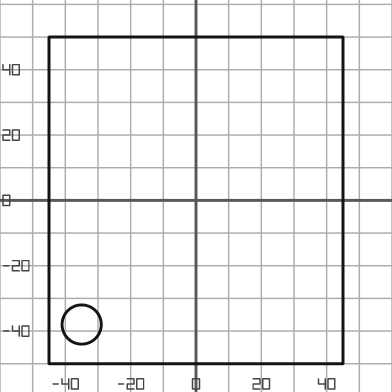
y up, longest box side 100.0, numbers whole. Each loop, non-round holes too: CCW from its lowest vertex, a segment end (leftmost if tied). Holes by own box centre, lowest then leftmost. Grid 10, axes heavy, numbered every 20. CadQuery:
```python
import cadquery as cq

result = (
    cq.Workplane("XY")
    .moveTo(-45.0, -50.0)
    .lineTo(45.0, -50.0)
    .lineTo(45.0, 50.0)
    .lineTo(-45.0, 50.0)
    .close()
    .moveTo(-35.0, -38.0)
    .circle(6.0)
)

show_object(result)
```